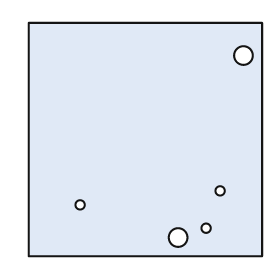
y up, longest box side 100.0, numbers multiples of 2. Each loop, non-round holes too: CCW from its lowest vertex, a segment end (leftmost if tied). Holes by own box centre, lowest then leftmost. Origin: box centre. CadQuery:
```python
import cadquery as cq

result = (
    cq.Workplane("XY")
    .moveTo(-50.0, -50.0)
    .lineTo(50.0, -50.0)
    .lineTo(50.0, 50.0)
    .lineTo(-50.0, 50.0)
    .close()
    .moveTo(14.0, -42.0)
    .circle(4.0)
    .moveTo(26.0, -38.0)
    .circle(2.0)
    .moveTo(-28.0, -28.0)
    .circle(2.0)
    .moveTo(32.0, -22.0)
    .circle(2.0)
    .moveTo(42.0, 36.0)
    .circle(4.0)
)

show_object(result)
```